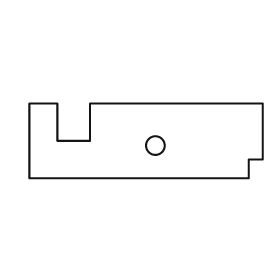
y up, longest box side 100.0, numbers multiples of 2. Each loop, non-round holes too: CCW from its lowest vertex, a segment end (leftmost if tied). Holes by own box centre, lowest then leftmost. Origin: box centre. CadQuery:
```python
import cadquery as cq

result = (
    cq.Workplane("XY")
    .moveTo(-50.0, -16.0)
    .lineTo(44.0, -16.0)
    .lineTo(44.0, -8.0)
    .lineTo(50.0, -8.0)
    .lineTo(50.0, 16.0)
    .lineTo(-24.0, 16.0)
    .lineTo(-24.0, 0.0)
    .lineTo(-38.0, 0.0)
    .lineTo(-38.0, 16.0)
    .lineTo(-50.0, 16.0)
    .close()
    .moveTo(4.0, -2.0)
    .circle(4.0)
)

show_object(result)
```